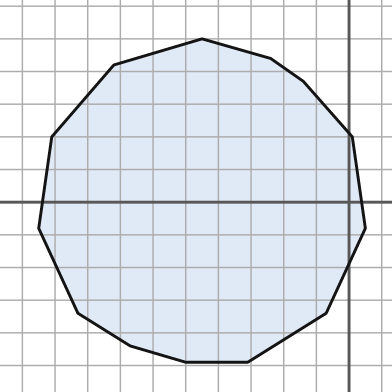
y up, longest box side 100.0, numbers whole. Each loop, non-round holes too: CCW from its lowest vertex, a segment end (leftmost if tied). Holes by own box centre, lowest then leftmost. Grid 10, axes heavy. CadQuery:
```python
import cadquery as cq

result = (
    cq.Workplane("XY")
    .moveTo(-50.0, -49.0)
    .lineTo(-31.0, -49.0)
    .lineTo(-7.0, -34.0)
    .lineTo(5.0, -8.0)
    .lineTo(1.0, 20.0)
    .lineTo(-14.0, 37.0)
    .lineTo(-24.0, 44.0)
    .lineTo(-45.0, 50.0)
    .lineTo(-72.0, 42.0)
    .lineTo(-91.0, 20.0)
    .lineTo(-95.0, -8.0)
    .lineTo(-83.0, -34.0)
    .lineTo(-67.0, -44.0)
    .close()
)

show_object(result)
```